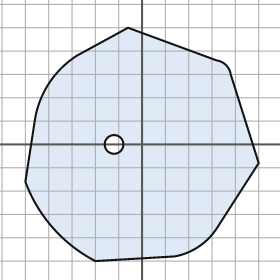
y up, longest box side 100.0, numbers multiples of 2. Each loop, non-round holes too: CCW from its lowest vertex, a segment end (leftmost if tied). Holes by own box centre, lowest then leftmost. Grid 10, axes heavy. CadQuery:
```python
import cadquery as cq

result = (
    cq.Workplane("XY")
    .moveTo(-20.0, -50.0)
    .lineTo(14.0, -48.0)
    .threePointArc((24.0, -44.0), (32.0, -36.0))
    .lineTo(50.0, -8.0)
    .lineTo(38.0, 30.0)
    .threePointArc((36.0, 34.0), (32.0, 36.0))
    .lineTo(-6.0, 50.0)
    .lineTo(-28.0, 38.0)
    .threePointArc((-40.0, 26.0), (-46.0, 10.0))
    .lineTo(-50.0, -16.0)
    .threePointArc((-38.0, -36.0), (-20.0, -50.0))
    .close()
    .moveTo(-12.0, 0.0)
    .circle(4.0)
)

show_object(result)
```